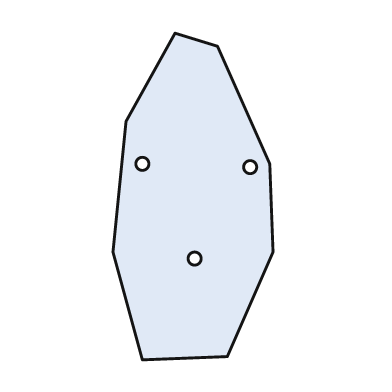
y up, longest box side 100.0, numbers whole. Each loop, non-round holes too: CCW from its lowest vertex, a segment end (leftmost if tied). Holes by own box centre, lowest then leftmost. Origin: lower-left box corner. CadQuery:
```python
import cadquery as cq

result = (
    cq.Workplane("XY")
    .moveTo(9.0, 0.0)
    .lineTo(35.0, 1.0)
    .lineTo(49.0, 33.0)
    .lineTo(48.0, 60.0)
    .lineTo(32.0, 96.0)
    .lineTo(19.0, 100.0)
    .lineTo(4.0, 73.0)
    .lineTo(0.0, 33.0)
    .close()
    .moveTo(25.0, 31.0)
    .circle(2.0)
    .moveTo(42.0, 59.0)
    .circle(2.0)
    .moveTo(9.0, 60.0)
    .circle(2.0)
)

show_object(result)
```